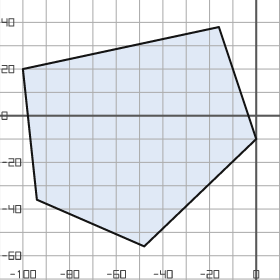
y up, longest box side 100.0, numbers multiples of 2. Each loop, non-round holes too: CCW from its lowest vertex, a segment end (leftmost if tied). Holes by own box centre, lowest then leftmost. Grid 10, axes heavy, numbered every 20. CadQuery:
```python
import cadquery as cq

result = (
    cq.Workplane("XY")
    .moveTo(-48.0, -56.0)
    .lineTo(0.0, -10.0)
    .lineTo(-16.0, 38.0)
    .lineTo(-100.0, 20.0)
    .lineTo(-94.0, -36.0)
    .close()
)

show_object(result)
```